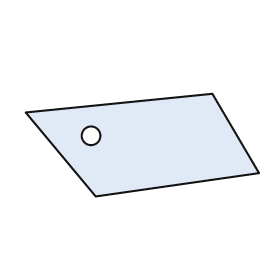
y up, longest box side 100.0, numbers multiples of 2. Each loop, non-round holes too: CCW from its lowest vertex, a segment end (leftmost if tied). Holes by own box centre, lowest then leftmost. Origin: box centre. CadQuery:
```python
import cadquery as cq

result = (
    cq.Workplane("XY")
    .moveTo(-20.0, -22.0)
    .lineTo(50.0, -12.0)
    .lineTo(30.0, 22.0)
    .lineTo(-50.0, 14.0)
    .close()
    .moveTo(-22.0, 4.0)
    .circle(4.0)
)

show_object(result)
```